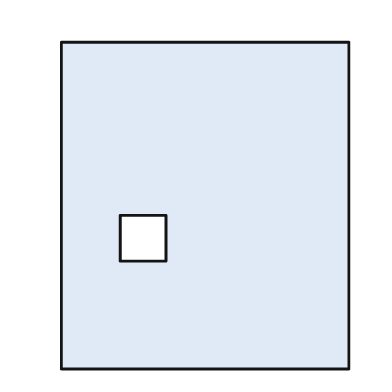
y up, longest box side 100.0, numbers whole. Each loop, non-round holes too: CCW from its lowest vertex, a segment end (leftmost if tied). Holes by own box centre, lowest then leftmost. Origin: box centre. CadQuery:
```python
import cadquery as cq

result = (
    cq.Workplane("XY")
    .moveTo(-44.0, -50.0)
    .lineTo(44.0, -50.0)
    .lineTo(44.0, 50.0)
    .lineTo(-44.0, 50.0)
    .close()
    .moveTo(-26.0, -17.0)
    .lineTo(-12.0, -17.0)
    .lineTo(-12.0, -3.0)
    .lineTo(-26.0, -3.0)
    .close()
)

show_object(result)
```